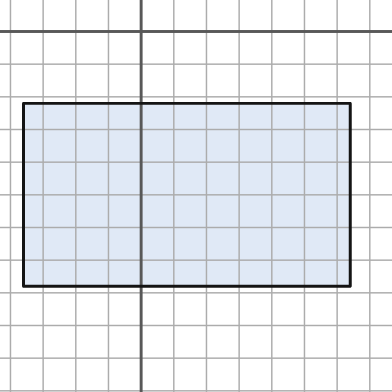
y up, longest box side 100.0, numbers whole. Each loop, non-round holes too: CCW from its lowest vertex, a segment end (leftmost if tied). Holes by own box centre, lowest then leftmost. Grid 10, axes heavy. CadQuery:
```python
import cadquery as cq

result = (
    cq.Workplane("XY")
    .moveTo(-36.0, -78.0)
    .lineTo(64.0, -78.0)
    .lineTo(64.0, -22.0)
    .lineTo(-36.0, -22.0)
    .close()
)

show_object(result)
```